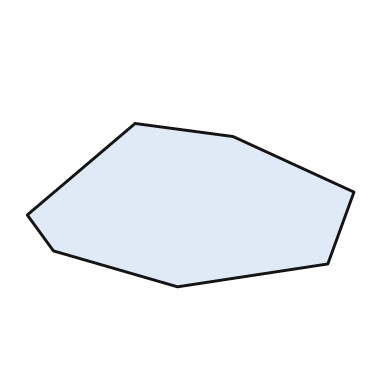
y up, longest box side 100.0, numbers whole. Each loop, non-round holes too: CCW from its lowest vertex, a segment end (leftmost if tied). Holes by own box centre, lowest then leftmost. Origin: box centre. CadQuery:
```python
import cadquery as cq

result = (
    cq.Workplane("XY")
    .moveTo(-4.0, -25.0)
    .lineTo(42.0, -18.0)
    .lineTo(50.0, 4.0)
    .lineTo(13.0, 21.0)
    .lineTo(-17.0, 25.0)
    .lineTo(-50.0, -3.0)
    .lineTo(-42.0, -14.0)
    .close()
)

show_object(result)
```